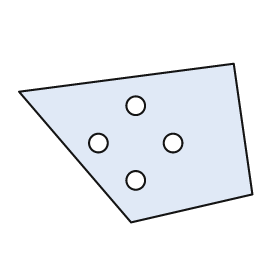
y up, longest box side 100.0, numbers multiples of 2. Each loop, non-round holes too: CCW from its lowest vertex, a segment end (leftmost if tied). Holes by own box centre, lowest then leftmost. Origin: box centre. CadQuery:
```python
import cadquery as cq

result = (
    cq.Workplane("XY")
    .moveTo(-2.0, -34.0)
    .lineTo(50.0, -22.0)
    .lineTo(42.0, 34.0)
    .lineTo(-50.0, 22.0)
    .close()
    .moveTo(0.0, -16.0)
    .circle(4.0)
    .moveTo(-16.0, 0.0)
    .circle(4.0)
    .moveTo(16.0, 0.0)
    .circle(4.0)
    .moveTo(0.0, 16.0)
    .circle(4.0)
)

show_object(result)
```